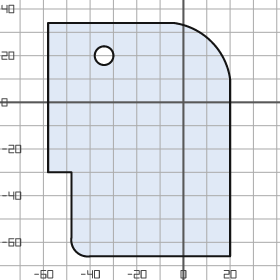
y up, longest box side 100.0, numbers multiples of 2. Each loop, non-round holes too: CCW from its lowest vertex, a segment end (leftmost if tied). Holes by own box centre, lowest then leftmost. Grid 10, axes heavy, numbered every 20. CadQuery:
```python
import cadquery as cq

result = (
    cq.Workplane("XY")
    .moveTo(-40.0, -66.0)
    .lineTo(20.0, -66.0)
    .lineTo(20.0, 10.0)
    .threePointArc((12.0, 26.0), (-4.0, 34.0))
    .lineTo(-58.0, 34.0)
    .lineTo(-58.0, -30.0)
    .lineTo(-48.0, -30.0)
    .lineTo(-48.0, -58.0)
    .threePointArc((-46.0, -64.0), (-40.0, -66.0))
    .close()
    .moveTo(-34.0, 20.0)
    .circle(4.0)
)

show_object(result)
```